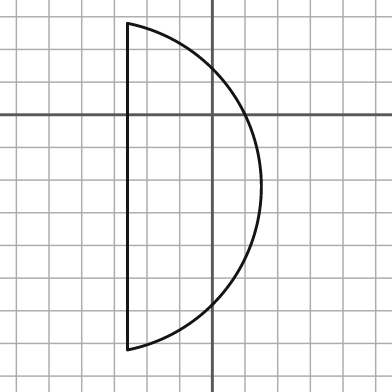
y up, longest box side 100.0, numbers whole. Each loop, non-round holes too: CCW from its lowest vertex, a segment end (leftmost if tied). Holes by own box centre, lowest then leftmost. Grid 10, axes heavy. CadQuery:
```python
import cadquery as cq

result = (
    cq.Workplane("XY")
    .moveTo(-26.0, -72.0)
    .threePointArc((15.0, -22.0), (-26.0, 28.0))
    .close()
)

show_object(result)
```